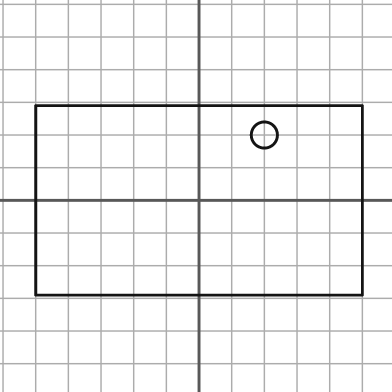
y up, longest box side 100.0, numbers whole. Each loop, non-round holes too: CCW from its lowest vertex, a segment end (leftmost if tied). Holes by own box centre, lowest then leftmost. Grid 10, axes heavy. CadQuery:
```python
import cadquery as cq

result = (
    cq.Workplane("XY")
    .moveTo(-50.0, -29.0)
    .lineTo(50.0, -29.0)
    .lineTo(50.0, 29.0)
    .lineTo(-50.0, 29.0)
    .close()
    .moveTo(20.0, 20.0)
    .circle(4.0)
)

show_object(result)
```